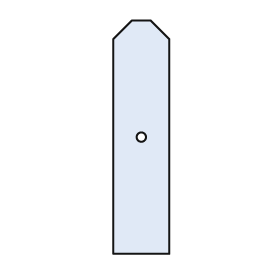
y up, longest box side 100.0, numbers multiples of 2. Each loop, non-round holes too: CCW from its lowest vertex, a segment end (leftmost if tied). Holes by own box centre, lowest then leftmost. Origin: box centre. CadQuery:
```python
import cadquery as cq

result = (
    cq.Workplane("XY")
    .moveTo(-12.0, -50.0)
    .lineTo(12.0, -50.0)
    .lineTo(12.0, 42.0)
    .lineTo(4.0, 50.0)
    .lineTo(-4.0, 50.0)
    .lineTo(-12.0, 42.0)
    .close()
    .moveTo(0.0, 0.0)
    .circle(2.0)
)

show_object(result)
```